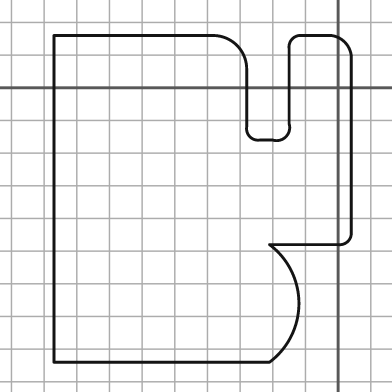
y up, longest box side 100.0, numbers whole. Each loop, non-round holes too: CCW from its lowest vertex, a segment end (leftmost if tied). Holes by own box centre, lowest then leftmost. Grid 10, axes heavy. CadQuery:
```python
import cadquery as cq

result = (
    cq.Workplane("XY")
    .moveTo(-87.0, -84.0)
    .lineTo(-21.0, -84.0)
    .threePointArc((-12.0, -66.0), (-21.0, -48.0))
    .lineTo(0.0, -48.0)
    .threePointArc((3.0, -47.0), (4.0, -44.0))
    .lineTo(4.0, 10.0)
    .threePointArc((2.0, 14.0), (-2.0, 16.0))
    .lineTo(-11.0, 16.0)
    .threePointArc((-14.0, 15.0), (-15.0, 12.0))
    .lineTo(-15.0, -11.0)
    .threePointArc((-16.0, -15.0), (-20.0, -16.0))
    .lineTo(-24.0, -16.0)
    .threePointArc((-27.0, -15.0), (-28.0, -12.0))
    .lineTo(-28.0, 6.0)
    .threePointArc((-31.0, 13.0), (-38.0, 16.0))
    .lineTo(-87.0, 16.0)
    .close()
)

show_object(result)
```